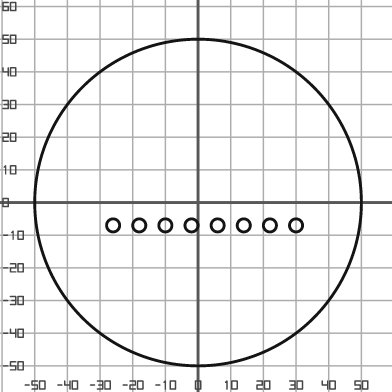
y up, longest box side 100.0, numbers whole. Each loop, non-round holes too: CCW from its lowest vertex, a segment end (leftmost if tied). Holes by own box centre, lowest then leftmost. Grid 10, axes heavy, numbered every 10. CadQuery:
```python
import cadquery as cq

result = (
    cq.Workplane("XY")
    .moveTo(0.0, 0.0)
    .circle(50.0)
    .moveTo(-26.0, -7.0)
    .circle(2.0)
    .moveTo(-18.0, -7.0)
    .circle(2.0)
    .moveTo(-10.0, -7.0)
    .circle(2.0)
    .moveTo(-2.0, -7.0)
    .circle(2.0)
    .moveTo(6.0, -7.0)
    .circle(2.0)
    .moveTo(14.0, -7.0)
    .circle(2.0)
    .moveTo(22.0, -7.0)
    .circle(2.0)
    .moveTo(30.0, -7.0)
    .circle(2.0)
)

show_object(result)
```